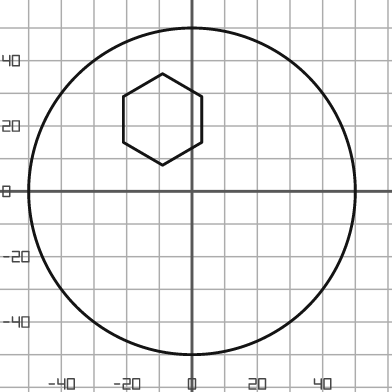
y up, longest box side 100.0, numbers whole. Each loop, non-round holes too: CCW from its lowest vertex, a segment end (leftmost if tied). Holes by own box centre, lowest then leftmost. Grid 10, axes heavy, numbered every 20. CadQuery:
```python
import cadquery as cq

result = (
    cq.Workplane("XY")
    .moveTo(0.0, 0.0)
    .circle(50.0)
    .moveTo(-9.0, 8.0)
    .lineTo(3.0, 15.0)
    .lineTo(3.0, 29.0)
    .lineTo(-9.0, 36.0)
    .lineTo(-21.0, 29.0)
    .lineTo(-21.0, 15.0)
    .close()
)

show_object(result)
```